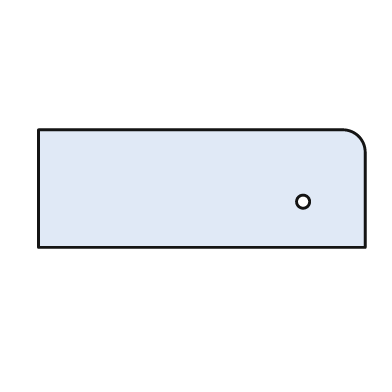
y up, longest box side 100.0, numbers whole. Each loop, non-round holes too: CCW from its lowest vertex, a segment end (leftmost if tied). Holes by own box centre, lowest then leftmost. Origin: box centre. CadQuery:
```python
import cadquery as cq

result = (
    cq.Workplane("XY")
    .moveTo(-50.0, -18.0)
    .lineTo(50.0, -18.0)
    .lineTo(50.0, 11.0)
    .threePointArc((48.0, 16.0), (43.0, 18.0))
    .lineTo(-50.0, 18.0)
    .close()
    .moveTo(31.0, -4.0)
    .circle(2.0)
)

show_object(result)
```